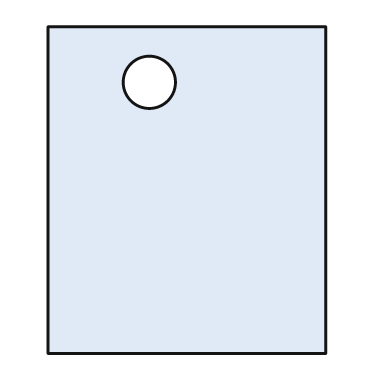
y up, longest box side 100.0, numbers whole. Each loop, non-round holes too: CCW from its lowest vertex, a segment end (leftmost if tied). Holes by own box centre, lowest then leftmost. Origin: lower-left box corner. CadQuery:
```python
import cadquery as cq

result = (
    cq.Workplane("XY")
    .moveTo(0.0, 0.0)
    .lineTo(85.0, 0.0)
    .lineTo(85.0, 100.0)
    .lineTo(0.0, 100.0)
    .close()
    .moveTo(31.0, 83.0)
    .circle(8.0)
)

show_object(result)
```